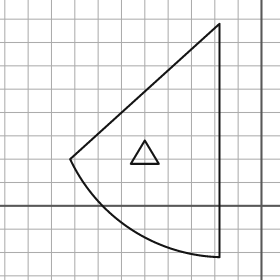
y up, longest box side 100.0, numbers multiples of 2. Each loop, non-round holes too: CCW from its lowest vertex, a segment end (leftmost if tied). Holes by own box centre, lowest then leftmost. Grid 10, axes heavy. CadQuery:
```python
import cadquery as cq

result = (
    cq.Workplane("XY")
    .moveTo(-18.0, -22.0)
    .lineTo(-18.0, 78.0)
    .lineTo(-82.0, 20.0)
    .threePointArc((-56.0, -10.0), (-18.0, -22.0))
    .close()
    .moveTo(-56.0, 18.0)
    .lineTo(-44.0, 18.0)
    .lineTo(-50.0, 28.0)
    .close()
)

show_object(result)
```